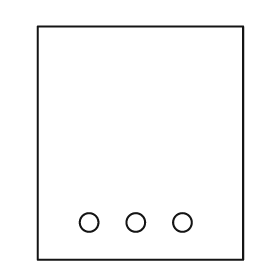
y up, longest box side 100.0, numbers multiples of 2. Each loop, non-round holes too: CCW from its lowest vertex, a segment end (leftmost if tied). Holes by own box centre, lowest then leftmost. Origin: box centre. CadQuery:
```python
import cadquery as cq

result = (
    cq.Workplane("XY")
    .moveTo(-44.0, -50.0)
    .lineTo(44.0, -50.0)
    .lineTo(44.0, 50.0)
    .lineTo(-44.0, 50.0)
    .close()
    .moveTo(-22.0, -34.0)
    .circle(4.0)
    .moveTo(-2.0, -34.0)
    .circle(4.0)
    .moveTo(18.0, -34.0)
    .circle(4.0)
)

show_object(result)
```